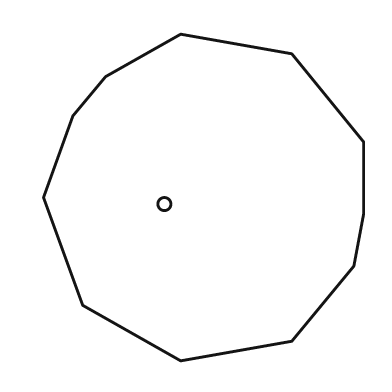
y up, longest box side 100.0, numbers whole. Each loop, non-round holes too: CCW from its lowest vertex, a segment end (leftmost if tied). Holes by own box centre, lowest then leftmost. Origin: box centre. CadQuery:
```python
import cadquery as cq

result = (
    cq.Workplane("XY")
    .moveTo(-7.0, -50.0)
    .lineTo(27.0, -44.0)
    .lineTo(46.0, -21.0)
    .lineTo(49.0, -5.0)
    .lineTo(49.0, 17.0)
    .lineTo(27.0, 44.0)
    .lineTo(-7.0, 50.0)
    .lineTo(-30.0, 37.0)
    .lineTo(-40.0, 25.0)
    .lineTo(-49.0, 0.0)
    .lineTo(-37.0, -33.0)
    .close()
    .moveTo(-12.0, -2.0)
    .circle(2.0)
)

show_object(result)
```